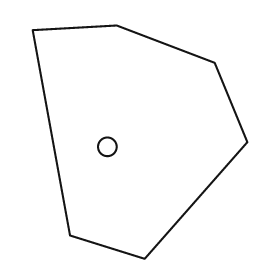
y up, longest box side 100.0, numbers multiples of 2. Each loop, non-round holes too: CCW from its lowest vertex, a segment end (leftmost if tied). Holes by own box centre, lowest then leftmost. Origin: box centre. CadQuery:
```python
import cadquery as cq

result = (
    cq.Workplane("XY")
    .moveTo(2.0, -50.0)
    .lineTo(46.0, 0.0)
    .lineTo(32.0, 34.0)
    .lineTo(-10.0, 50.0)
    .lineTo(-46.0, 48.0)
    .lineTo(-30.0, -40.0)
    .close()
    .moveTo(-14.0, -2.0)
    .circle(4.0)
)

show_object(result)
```